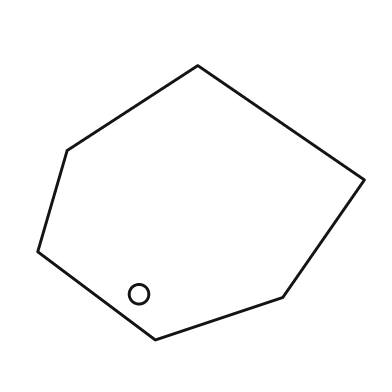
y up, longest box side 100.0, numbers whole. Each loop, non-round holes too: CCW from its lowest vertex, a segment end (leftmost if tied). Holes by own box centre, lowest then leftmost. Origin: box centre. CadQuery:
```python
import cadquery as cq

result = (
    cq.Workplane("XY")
    .moveTo(-14.0, -42.0)
    .lineTo(25.0, -29.0)
    .lineTo(50.0, 7.0)
    .lineTo(-1.0, 42.0)
    .lineTo(-41.0, 16.0)
    .lineTo(-50.0, -15.0)
    .close()
    .moveTo(-19.0, -28.0)
    .circle(3.0)
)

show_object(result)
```